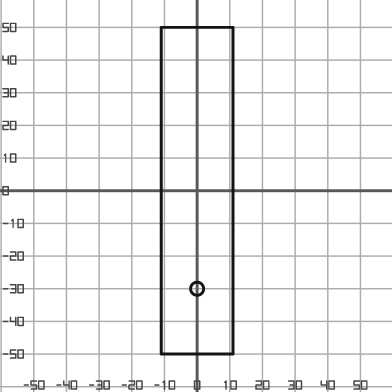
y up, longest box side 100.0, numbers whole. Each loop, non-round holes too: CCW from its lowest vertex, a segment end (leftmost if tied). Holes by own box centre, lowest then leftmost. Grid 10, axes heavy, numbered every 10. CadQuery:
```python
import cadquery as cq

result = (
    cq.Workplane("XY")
    .moveTo(-11.0, -50.0)
    .lineTo(11.0, -50.0)
    .lineTo(11.0, 50.0)
    .lineTo(-11.0, 50.0)
    .close()
    .moveTo(0.0, -30.0)
    .circle(2.0)
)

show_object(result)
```